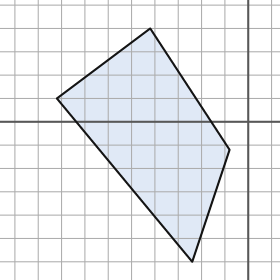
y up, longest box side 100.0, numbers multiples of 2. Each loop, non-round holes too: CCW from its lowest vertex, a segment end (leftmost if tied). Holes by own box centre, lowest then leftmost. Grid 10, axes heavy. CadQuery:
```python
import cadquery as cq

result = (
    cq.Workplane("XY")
    .moveTo(-24.0, -60.0)
    .lineTo(-8.0, -12.0)
    .lineTo(-42.0, 40.0)
    .lineTo(-82.0, 10.0)
    .close()
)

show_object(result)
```